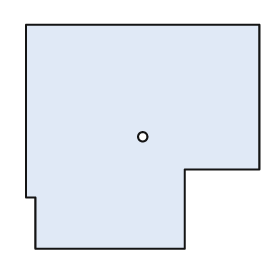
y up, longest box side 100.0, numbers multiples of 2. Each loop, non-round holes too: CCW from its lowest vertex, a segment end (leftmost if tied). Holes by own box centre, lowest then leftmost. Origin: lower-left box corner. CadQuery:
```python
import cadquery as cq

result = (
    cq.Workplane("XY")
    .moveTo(4.0, 0.0)
    .lineTo(68.0, 0.0)
    .lineTo(68.0, 34.0)
    .lineTo(100.0, 34.0)
    .lineTo(100.0, 96.0)
    .lineTo(0.0, 96.0)
    .lineTo(0.0, 22.0)
    .lineTo(4.0, 22.0)
    .close()
    .moveTo(50.0, 48.0)
    .circle(2.0)
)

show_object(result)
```